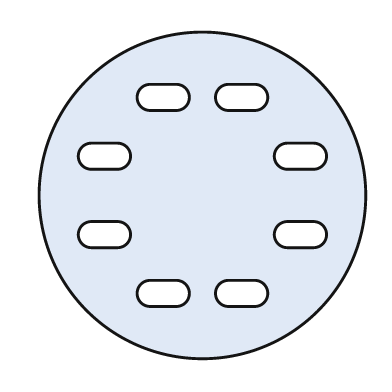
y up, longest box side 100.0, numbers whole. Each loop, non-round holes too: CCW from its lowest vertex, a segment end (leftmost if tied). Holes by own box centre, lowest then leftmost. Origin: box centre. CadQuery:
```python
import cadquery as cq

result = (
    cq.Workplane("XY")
    .moveTo(0.0, 0.0)
    .circle(50.0)
    .moveTo(-16.0, -34.0)
    .lineTo(-8.0, -34.0)
    .threePointArc((-4.0, -30.0), (-8.0, -26.0))
    .lineTo(-16.0, -26.0)
    .threePointArc((-20.0, -30.0), (-16.0, -34.0))
    .close()
    .moveTo(8.0, -34.0)
    .lineTo(16.0, -34.0)
    .threePointArc((20.0, -30.0), (16.0, -26.0))
    .lineTo(8.0, -26.0)
    .threePointArc((4.0, -30.0), (8.0, -34.0))
    .close()
    .moveTo(-34.0, -16.0)
    .lineTo(-26.0, -16.0)
    .threePointArc((-22.0, -12.0), (-26.0, -8.0))
    .lineTo(-34.0, -8.0)
    .threePointArc((-38.0, -12.0), (-34.0, -16.0))
    .close()
    .moveTo(26.0, -16.0)
    .lineTo(34.0, -16.0)
    .threePointArc((38.0, -12.0), (34.0, -8.0))
    .lineTo(26.0, -8.0)
    .threePointArc((22.0, -12.0), (26.0, -16.0))
    .close()
    .moveTo(-34.0, 8.0)
    .lineTo(-26.0, 8.0)
    .threePointArc((-22.0, 12.0), (-26.0, 16.0))
    .lineTo(-34.0, 16.0)
    .threePointArc((-38.0, 12.0), (-34.0, 8.0))
    .close()
    .moveTo(26.0, 8.0)
    .lineTo(34.0, 8.0)
    .threePointArc((38.0, 12.0), (34.0, 16.0))
    .lineTo(26.0, 16.0)
    .threePointArc((22.0, 12.0), (26.0, 8.0))
    .close()
    .moveTo(-16.0, 26.0)
    .lineTo(-8.0, 26.0)
    .threePointArc((-4.0, 30.0), (-8.0, 34.0))
    .lineTo(-16.0, 34.0)
    .threePointArc((-20.0, 30.0), (-16.0, 26.0))
    .close()
    .moveTo(8.0, 26.0)
    .lineTo(16.0, 26.0)
    .threePointArc((20.0, 30.0), (16.0, 34.0))
    .lineTo(8.0, 34.0)
    .threePointArc((4.0, 30.0), (8.0, 26.0))
    .close()
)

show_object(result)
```